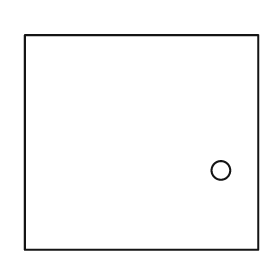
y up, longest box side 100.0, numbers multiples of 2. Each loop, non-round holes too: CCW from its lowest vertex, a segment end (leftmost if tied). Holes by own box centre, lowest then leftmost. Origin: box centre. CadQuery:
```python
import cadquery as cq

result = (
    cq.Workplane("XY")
    .moveTo(-50.0, -46.0)
    .lineTo(50.0, -46.0)
    .lineTo(50.0, 46.0)
    .lineTo(-50.0, 46.0)
    .close()
    .moveTo(34.0, -12.0)
    .circle(4.0)
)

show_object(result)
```